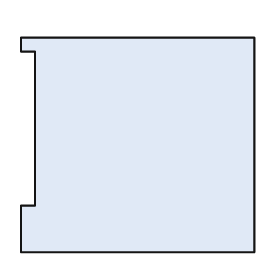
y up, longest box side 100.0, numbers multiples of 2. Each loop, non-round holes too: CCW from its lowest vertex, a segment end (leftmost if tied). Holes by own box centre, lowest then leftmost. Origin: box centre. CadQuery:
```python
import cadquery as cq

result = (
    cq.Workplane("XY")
    .moveTo(-50.0, -46.0)
    .lineTo(50.0, -46.0)
    .lineTo(50.0, 46.0)
    .lineTo(-50.0, 46.0)
    .lineTo(-50.0, 40.0)
    .lineTo(-44.0, 40.0)
    .lineTo(-44.0, -26.0)
    .lineTo(-50.0, -26.0)
    .close()
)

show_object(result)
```